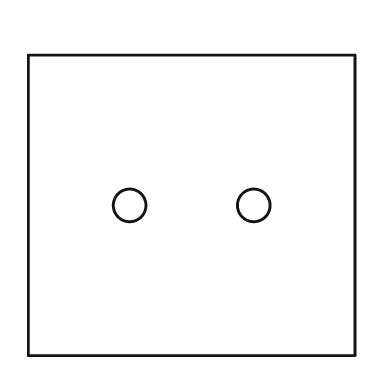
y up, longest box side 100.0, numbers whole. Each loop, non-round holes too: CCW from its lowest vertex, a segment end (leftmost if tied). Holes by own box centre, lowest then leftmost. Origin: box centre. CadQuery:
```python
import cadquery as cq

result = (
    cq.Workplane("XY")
    .moveTo(-50.0, -46.0)
    .lineTo(50.0, -46.0)
    .lineTo(50.0, 46.0)
    .lineTo(-50.0, 46.0)
    .close()
    .moveTo(-19.0, 0.0)
    .circle(5.0)
    .moveTo(19.0, 0.0)
    .circle(5.0)
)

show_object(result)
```